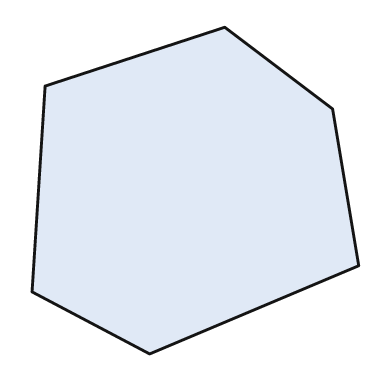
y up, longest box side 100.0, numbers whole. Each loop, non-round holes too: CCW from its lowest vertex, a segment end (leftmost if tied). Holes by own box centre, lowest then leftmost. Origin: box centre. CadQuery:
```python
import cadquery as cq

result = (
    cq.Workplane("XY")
    .moveTo(-14.0, -50.0)
    .lineTo(50.0, -23.0)
    .lineTo(42.0, 25.0)
    .lineTo(9.0, 50.0)
    .lineTo(-46.0, 32.0)
    .lineTo(-50.0, -31.0)
    .close()
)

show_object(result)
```